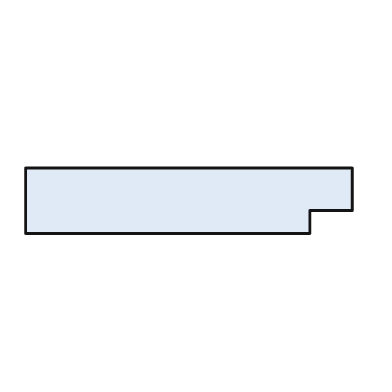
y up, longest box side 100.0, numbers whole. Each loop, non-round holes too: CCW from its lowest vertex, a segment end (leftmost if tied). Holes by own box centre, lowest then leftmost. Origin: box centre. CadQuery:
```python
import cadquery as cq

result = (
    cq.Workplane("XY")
    .moveTo(-50.0, -10.0)
    .lineTo(37.0, -10.0)
    .lineTo(37.0, -3.0)
    .lineTo(50.0, -3.0)
    .lineTo(50.0, 10.0)
    .lineTo(-50.0, 10.0)
    .close()
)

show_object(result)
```